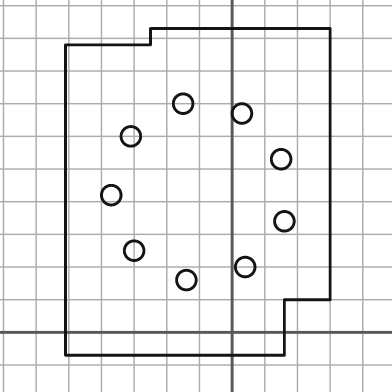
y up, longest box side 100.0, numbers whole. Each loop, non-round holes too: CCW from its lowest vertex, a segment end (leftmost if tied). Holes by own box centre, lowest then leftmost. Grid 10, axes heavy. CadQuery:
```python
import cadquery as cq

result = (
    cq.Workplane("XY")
    .moveTo(-51.0, -7.0)
    .lineTo(16.0, -7.0)
    .lineTo(16.0, 10.0)
    .lineTo(30.0, 10.0)
    .lineTo(30.0, 93.0)
    .lineTo(-25.0, 93.0)
    .lineTo(-25.0, 88.0)
    .lineTo(-51.0, 88.0)
    .close()
    .moveTo(-14.0, 16.0)
    .circle(3.0)
    .moveTo(4.0, 20.0)
    .circle(3.0)
    .moveTo(-30.0, 25.0)
    .circle(3.0)
    .moveTo(16.0, 34.0)
    .circle(3.0)
    .moveTo(-37.0, 42.0)
    .circle(3.0)
    .moveTo(15.0, 53.0)
    .circle(3.0)
    .moveTo(-31.0, 60.0)
    .circle(3.0)
    .moveTo(3.0, 67.0)
    .circle(3.0)
    .moveTo(-15.0, 70.0)
    .circle(3.0)
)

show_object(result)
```